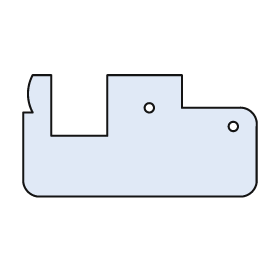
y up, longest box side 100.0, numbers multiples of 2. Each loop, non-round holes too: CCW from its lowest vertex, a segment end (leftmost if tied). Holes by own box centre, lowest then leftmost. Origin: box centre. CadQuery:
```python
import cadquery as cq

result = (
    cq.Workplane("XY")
    .moveTo(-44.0, -26.0)
    .lineTo(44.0, -26.0)
    .threePointArc((48.0, -24.0), (50.0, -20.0))
    .lineTo(50.0, 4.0)
    .threePointArc((48.0, 10.0), (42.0, 12.0))
    .lineTo(18.0, 12.0)
    .lineTo(18.0, 26.0)
    .lineTo(-14.0, 26.0)
    .lineTo(-14.0, 0.0)
    .lineTo(-38.0, 0.0)
    .lineTo(-38.0, 26.0)
    .lineTo(-46.0, 26.0)
    .threePointArc((-48.0, 18.0), (-46.0, 10.0))
    .lineTo(-50.0, 10.0)
    .lineTo(-50.0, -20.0)
    .threePointArc((-48.0, -24.0), (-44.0, -26.0))
    .close()
    .moveTo(40.0, 4.0)
    .circle(2.0)
    .moveTo(4.0, 12.0)
    .circle(2.0)
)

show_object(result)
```